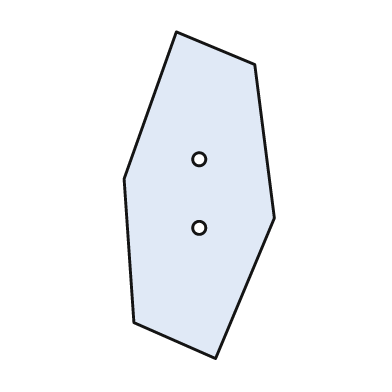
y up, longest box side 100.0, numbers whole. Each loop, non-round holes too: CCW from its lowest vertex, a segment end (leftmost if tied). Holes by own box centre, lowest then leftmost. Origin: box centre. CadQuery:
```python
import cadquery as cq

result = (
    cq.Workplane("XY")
    .moveTo(5.0, -50.0)
    .lineTo(23.0, -7.0)
    .lineTo(17.0, 40.0)
    .lineTo(-7.0, 50.0)
    .lineTo(-23.0, 5.0)
    .lineTo(-20.0, -39.0)
    .close()
    .moveTo(0.0, -10.0)
    .circle(2.0)
    .moveTo(0.0, 11.0)
    .circle(2.0)
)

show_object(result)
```